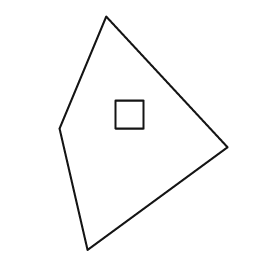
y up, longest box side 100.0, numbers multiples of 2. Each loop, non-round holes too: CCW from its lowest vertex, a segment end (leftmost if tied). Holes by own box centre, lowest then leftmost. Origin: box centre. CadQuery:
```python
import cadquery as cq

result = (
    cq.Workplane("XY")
    .moveTo(-24.0, -50.0)
    .lineTo(36.0, -6.0)
    .lineTo(-16.0, 50.0)
    .lineTo(-36.0, 2.0)
    .close()
    .moveTo(-12.0, 2.0)
    .lineTo(0.0, 2.0)
    .lineTo(0.0, 14.0)
    .lineTo(-12.0, 14.0)
    .close()
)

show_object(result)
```